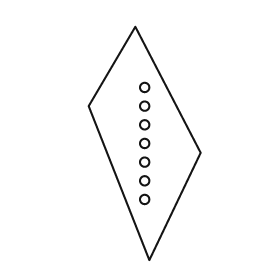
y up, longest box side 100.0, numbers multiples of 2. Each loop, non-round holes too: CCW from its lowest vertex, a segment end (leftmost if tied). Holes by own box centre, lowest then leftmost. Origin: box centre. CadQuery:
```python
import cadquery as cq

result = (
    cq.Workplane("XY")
    .moveTo(2.0, -50.0)
    .lineTo(24.0, -4.0)
    .lineTo(-4.0, 50.0)
    .lineTo(-24.0, 16.0)
    .close()
    .moveTo(0.0, -24.0)
    .circle(2.0)
    .moveTo(0.0, -16.0)
    .circle(2.0)
    .moveTo(0.0, -8.0)
    .circle(2.0)
    .moveTo(0.0, 0.0)
    .circle(2.0)
    .moveTo(0.0, 8.0)
    .circle(2.0)
    .moveTo(0.0, 16.0)
    .circle(2.0)
    .moveTo(0.0, 24.0)
    .circle(2.0)
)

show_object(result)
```